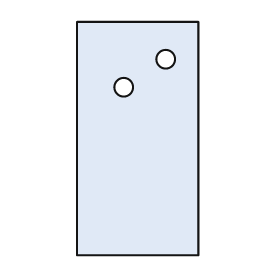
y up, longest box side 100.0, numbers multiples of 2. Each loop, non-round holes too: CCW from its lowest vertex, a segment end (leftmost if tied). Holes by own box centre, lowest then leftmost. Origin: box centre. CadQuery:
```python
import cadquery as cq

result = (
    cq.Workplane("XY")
    .moveTo(-26.0, -50.0)
    .lineTo(26.0, -50.0)
    .lineTo(26.0, 50.0)
    .lineTo(-26.0, 50.0)
    .close()
    .moveTo(-6.0, 22.0)
    .circle(4.0)
    .moveTo(12.0, 34.0)
    .circle(4.0)
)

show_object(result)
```